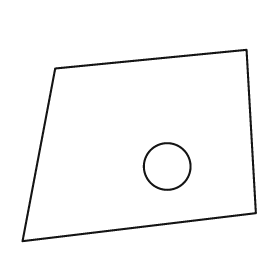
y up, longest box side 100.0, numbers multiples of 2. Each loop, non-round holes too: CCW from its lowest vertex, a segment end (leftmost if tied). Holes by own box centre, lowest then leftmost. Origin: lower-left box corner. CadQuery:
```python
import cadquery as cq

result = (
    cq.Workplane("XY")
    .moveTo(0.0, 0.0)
    .lineTo(100.0, 12.0)
    .lineTo(96.0, 82.0)
    .lineTo(14.0, 74.0)
    .close()
    .moveTo(62.0, 32.0)
    .circle(10.0)
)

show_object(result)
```